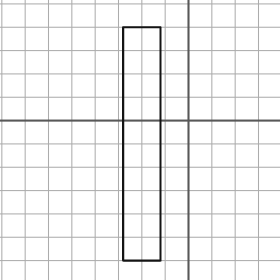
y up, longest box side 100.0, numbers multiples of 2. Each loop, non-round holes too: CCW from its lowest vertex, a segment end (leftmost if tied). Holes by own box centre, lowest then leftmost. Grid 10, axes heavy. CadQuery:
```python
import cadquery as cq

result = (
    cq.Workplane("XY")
    .moveTo(-28.0, -60.0)
    .lineTo(-12.0, -60.0)
    .lineTo(-12.0, 40.0)
    .lineTo(-28.0, 40.0)
    .close()
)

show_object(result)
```